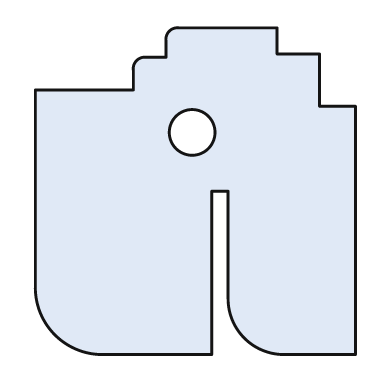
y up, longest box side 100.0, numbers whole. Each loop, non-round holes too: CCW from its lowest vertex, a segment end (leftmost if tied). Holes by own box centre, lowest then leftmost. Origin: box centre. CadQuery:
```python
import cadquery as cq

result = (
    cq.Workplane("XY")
    .moveTo(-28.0, -50.0)
    .lineTo(5.0, -50.0)
    .lineTo(5.0, 0.0)
    .lineTo(10.0, 0.0)
    .lineTo(10.0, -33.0)
    .threePointArc((15.0, -45.0), (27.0, -50.0))
    .lineTo(49.0, -50.0)
    .lineTo(49.0, 26.0)
    .lineTo(38.0, 26.0)
    .lineTo(38.0, 42.0)
    .lineTo(25.0, 42.0)
    .lineTo(25.0, 50.0)
    .lineTo(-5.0, 50.0)
    .threePointArc((-8.0, 49.0), (-9.0, 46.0))
    .lineTo(-9.0, 41.0)
    .lineTo(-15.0, 41.0)
    .threePointArc((-18.0, 40.0), (-19.0, 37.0))
    .lineTo(-19.0, 31.0)
    .lineTo(-49.0, 31.0)
    .lineTo(-49.0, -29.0)
    .threePointArc((-43.0, -44.0), (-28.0, -50.0))
    .close()
    .moveTo(-1.0, 18.0)
    .circle(7.0)
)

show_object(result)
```